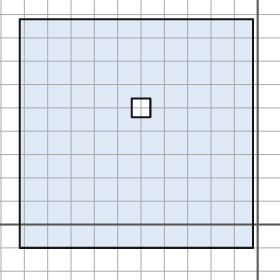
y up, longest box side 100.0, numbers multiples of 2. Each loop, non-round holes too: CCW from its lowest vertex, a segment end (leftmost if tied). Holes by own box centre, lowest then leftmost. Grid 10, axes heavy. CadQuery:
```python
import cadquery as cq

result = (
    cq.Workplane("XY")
    .moveTo(-102.0, -10.0)
    .lineTo(-2.0, -10.0)
    .lineTo(-2.0, 88.0)
    .lineTo(-102.0, 88.0)
    .close()
    .moveTo(-54.0, 46.0)
    .lineTo(-46.0, 46.0)
    .lineTo(-46.0, 54.0)
    .lineTo(-54.0, 54.0)
    .close()
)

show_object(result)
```